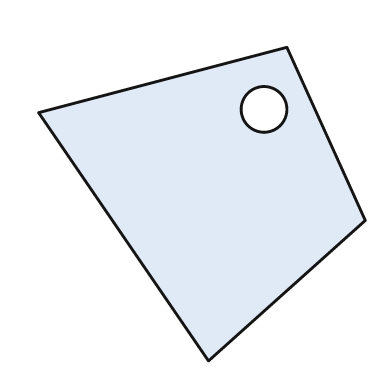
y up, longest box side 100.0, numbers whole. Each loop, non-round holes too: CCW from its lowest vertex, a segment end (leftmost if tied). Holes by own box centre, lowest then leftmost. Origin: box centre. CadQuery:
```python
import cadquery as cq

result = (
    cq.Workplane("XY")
    .moveTo(2.0, -48.0)
    .lineTo(50.0, -5.0)
    .lineTo(26.0, 48.0)
    .lineTo(-50.0, 28.0)
    .close()
    .moveTo(19.0, 29.0)
    .circle(7.0)
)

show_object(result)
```